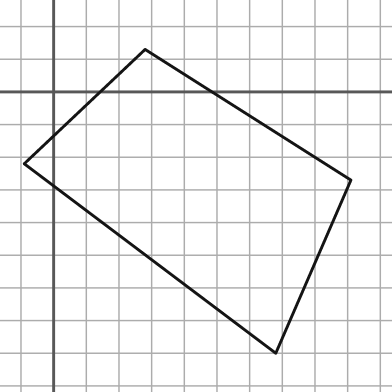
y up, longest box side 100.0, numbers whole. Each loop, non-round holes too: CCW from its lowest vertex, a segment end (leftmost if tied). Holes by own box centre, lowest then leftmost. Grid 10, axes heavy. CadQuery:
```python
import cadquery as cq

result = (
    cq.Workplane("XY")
    .moveTo(68.0, -80.0)
    .lineTo(91.0, -27.0)
    .lineTo(28.0, 13.0)
    .lineTo(-9.0, -22.0)
    .close()
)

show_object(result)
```